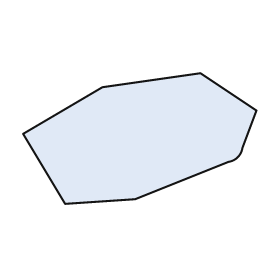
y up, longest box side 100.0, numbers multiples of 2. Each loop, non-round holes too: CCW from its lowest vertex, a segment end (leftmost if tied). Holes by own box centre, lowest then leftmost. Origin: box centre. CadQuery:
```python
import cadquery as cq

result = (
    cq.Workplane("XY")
    .moveTo(-32.0, -28.0)
    .lineTo(-2.0, -26.0)
    .lineTo(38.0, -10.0)
    .threePointArc((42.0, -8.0), (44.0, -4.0))
    .lineTo(50.0, 12.0)
    .lineTo(26.0, 28.0)
    .lineTo(-16.0, 22.0)
    .lineTo(-50.0, 2.0)
    .close()
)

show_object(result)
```